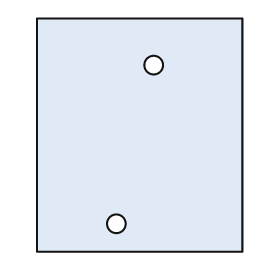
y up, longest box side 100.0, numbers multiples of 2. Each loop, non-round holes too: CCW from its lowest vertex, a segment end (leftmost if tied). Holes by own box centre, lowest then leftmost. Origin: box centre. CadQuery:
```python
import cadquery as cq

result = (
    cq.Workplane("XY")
    .moveTo(-44.0, -50.0)
    .lineTo(44.0, -50.0)
    .lineTo(44.0, 50.0)
    .lineTo(-44.0, 50.0)
    .close()
    .moveTo(-10.0, -38.0)
    .circle(4.0)
    .moveTo(6.0, 30.0)
    .circle(4.0)
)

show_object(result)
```